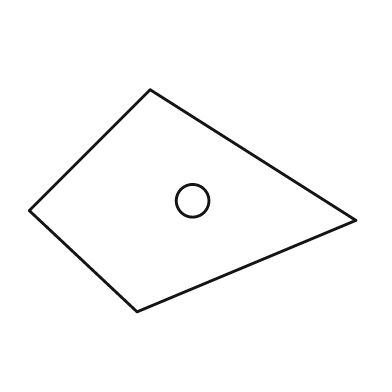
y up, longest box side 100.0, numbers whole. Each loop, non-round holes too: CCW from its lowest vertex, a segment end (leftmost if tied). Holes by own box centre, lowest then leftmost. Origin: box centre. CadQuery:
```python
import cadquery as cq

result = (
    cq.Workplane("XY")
    .moveTo(-17.0, -34.0)
    .lineTo(50.0, -6.0)
    .lineTo(-13.0, 34.0)
    .lineTo(-50.0, -3.0)
    .close()
    .moveTo(0.0, 0.0)
    .circle(5.0)
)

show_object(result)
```